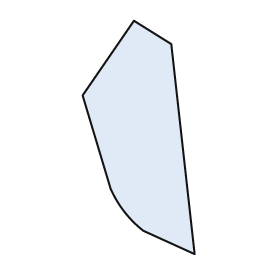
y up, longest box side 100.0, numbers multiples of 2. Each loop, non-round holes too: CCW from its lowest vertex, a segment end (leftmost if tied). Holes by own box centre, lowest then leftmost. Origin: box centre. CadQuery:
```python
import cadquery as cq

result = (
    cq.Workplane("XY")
    .moveTo(24.0, -50.0)
    .lineTo(14.0, 40.0)
    .lineTo(-2.0, 50.0)
    .lineTo(-24.0, 18.0)
    .lineTo(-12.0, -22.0)
    .threePointArc((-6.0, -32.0), (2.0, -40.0))
    .close()
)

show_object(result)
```